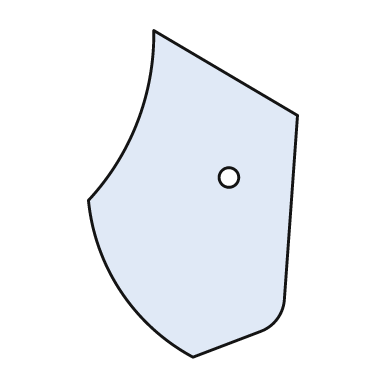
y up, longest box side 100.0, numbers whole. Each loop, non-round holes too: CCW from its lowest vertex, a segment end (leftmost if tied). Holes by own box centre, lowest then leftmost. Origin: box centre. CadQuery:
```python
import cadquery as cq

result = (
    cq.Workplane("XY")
    .moveTo(0.0, -50.0)
    .lineTo(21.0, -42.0)
    .threePointArc((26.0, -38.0), (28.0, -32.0))
    .lineTo(32.0, 24.0)
    .lineTo(-12.0, 50.0)
    .threePointArc((-17.0, 22.0), (-32.0, -2.0))
    .threePointArc((-22.0, -30.0), (0.0, -50.0))
    .close()
    .moveTo(11.0, 5.0)
    .circle(3.0)
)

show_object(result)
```